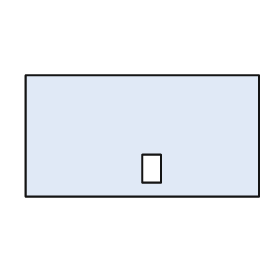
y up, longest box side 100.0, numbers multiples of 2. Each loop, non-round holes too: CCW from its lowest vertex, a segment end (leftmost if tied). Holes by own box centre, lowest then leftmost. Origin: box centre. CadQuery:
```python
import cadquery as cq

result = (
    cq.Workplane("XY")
    .moveTo(-50.0, -26.0)
    .lineTo(50.0, -26.0)
    .lineTo(50.0, 26.0)
    .lineTo(-50.0, 26.0)
    .close()
    .moveTo(0.0, -20.0)
    .lineTo(8.0, -20.0)
    .lineTo(8.0, -8.0)
    .lineTo(0.0, -8.0)
    .close()
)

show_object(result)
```